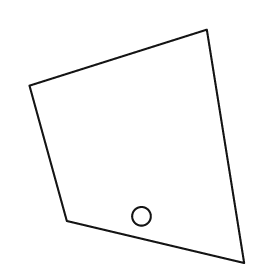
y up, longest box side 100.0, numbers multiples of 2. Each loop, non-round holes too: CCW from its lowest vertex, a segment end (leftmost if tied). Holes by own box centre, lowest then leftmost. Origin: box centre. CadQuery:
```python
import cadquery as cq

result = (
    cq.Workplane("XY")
    .moveTo(46.0, -50.0)
    .lineTo(30.0, 50.0)
    .lineTo(-46.0, 26.0)
    .lineTo(-30.0, -32.0)
    .close()
    .moveTo(2.0, -30.0)
    .circle(4.0)
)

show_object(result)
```